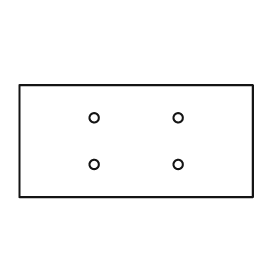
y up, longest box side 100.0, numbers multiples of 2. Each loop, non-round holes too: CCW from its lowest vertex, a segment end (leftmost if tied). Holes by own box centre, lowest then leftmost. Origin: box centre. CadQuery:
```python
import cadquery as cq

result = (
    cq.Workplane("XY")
    .moveTo(-50.0, -24.0)
    .lineTo(50.0, -24.0)
    .lineTo(50.0, 24.0)
    .lineTo(-50.0, 24.0)
    .close()
    .moveTo(-18.0, -10.0)
    .circle(2.0)
    .moveTo(18.0, -10.0)
    .circle(2.0)
    .moveTo(-18.0, 10.0)
    .circle(2.0)
    .moveTo(18.0, 10.0)
    .circle(2.0)
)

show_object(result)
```